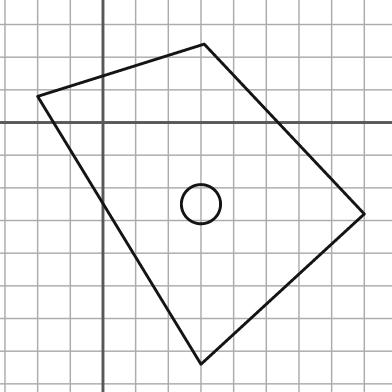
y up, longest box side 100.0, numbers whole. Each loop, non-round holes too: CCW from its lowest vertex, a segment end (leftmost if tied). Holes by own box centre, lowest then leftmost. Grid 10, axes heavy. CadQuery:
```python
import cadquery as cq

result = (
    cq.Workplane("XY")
    .moveTo(30.0, -74.0)
    .lineTo(80.0, -28.0)
    .lineTo(31.0, 24.0)
    .lineTo(-20.0, 8.0)
    .close()
    .moveTo(30.0, -25.0)
    .circle(6.0)
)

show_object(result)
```